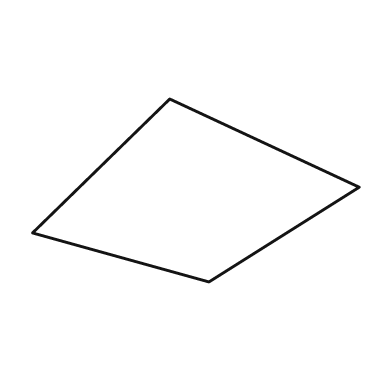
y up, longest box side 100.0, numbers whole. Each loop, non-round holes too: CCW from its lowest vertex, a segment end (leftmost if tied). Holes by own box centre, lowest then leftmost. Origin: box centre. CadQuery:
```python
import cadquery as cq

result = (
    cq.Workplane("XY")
    .moveTo(4.0, -28.0)
    .lineTo(50.0, 1.0)
    .lineTo(-8.0, 28.0)
    .lineTo(-50.0, -13.0)
    .close()
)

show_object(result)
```